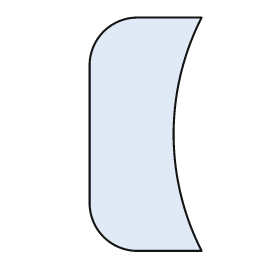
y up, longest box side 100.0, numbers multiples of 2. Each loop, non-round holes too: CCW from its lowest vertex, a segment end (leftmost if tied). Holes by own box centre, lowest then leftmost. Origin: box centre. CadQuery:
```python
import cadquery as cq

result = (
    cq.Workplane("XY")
    .moveTo(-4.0, -50.0)
    .lineTo(24.0, -50.0)
    .threePointArc((12.0, 0.0), (24.0, 50.0))
    .lineTo(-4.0, 50.0)
    .threePointArc((-18.0, 44.0), (-24.0, 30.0))
    .lineTo(-24.0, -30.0)
    .threePointArc((-18.0, -44.0), (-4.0, -50.0))
    .close()
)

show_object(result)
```